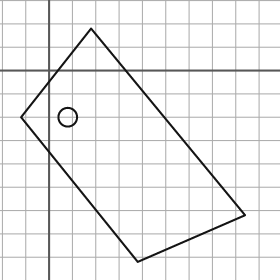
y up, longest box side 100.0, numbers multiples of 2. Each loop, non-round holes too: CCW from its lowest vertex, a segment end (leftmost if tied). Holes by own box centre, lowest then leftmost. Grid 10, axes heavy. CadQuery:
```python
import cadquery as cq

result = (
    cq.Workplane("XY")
    .moveTo(38.0, -82.0)
    .lineTo(84.0, -62.0)
    .lineTo(18.0, 18.0)
    .lineTo(-12.0, -20.0)
    .close()
    .moveTo(8.0, -20.0)
    .circle(4.0)
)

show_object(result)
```